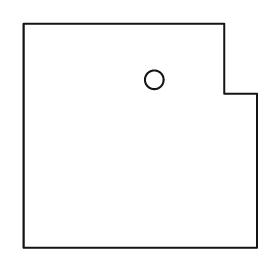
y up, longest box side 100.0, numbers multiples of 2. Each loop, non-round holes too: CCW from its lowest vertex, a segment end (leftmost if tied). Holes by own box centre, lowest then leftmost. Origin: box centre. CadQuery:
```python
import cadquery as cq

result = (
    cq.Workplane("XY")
    .moveTo(-50.0, -48.0)
    .lineTo(50.0, -48.0)
    .lineTo(50.0, 18.0)
    .lineTo(36.0, 18.0)
    .lineTo(36.0, 48.0)
    .lineTo(-50.0, 48.0)
    .close()
    .moveTo(6.0, 24.0)
    .circle(4.0)
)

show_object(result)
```